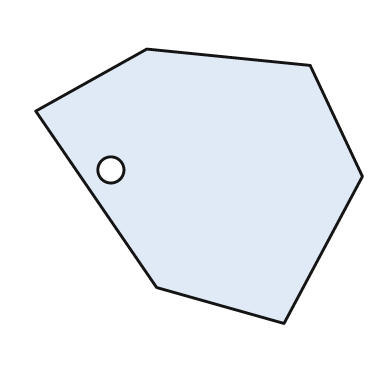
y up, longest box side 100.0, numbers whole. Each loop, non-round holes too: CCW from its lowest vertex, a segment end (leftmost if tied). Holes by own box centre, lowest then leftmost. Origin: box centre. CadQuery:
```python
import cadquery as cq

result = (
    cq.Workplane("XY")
    .moveTo(26.0, -42.0)
    .lineTo(50.0, 3.0)
    .lineTo(34.0, 37.0)
    .lineTo(-16.0, 42.0)
    .lineTo(-50.0, 23.0)
    .lineTo(-13.0, -31.0)
    .close()
    .moveTo(-27.0, 5.0)
    .circle(4.0)
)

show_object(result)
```